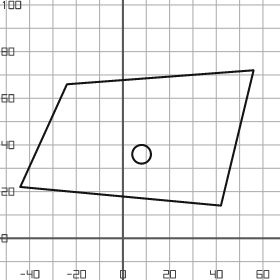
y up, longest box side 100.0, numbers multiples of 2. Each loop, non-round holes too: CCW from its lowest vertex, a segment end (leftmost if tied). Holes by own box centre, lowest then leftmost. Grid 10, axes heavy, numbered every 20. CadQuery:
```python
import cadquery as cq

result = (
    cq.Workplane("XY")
    .moveTo(42.0, 14.0)
    .lineTo(56.0, 72.0)
    .lineTo(-24.0, 66.0)
    .lineTo(-44.0, 22.0)
    .close()
    .moveTo(8.0, 36.0)
    .circle(4.0)
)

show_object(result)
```